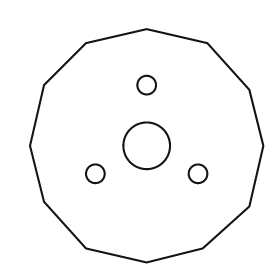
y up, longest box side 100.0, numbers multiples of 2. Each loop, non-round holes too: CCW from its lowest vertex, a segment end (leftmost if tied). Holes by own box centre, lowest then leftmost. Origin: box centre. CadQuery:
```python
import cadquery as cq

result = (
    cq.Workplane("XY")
    .moveTo(0.0, -50.0)
    .lineTo(24.0, -44.0)
    .lineTo(44.0, -26.0)
    .lineTo(50.0, 0.0)
    .lineTo(44.0, 24.0)
    .lineTo(26.0, 44.0)
    .lineTo(0.0, 50.0)
    .lineTo(-26.0, 44.0)
    .lineTo(-44.0, 26.0)
    .lineTo(-50.0, 0.0)
    .lineTo(-44.0, -24.0)
    .lineTo(-26.0, -44.0)
    .close()
    .moveTo(-22.0, -12.0)
    .circle(4.0)
    .moveTo(22.0, -12.0)
    .circle(4.0)
    .moveTo(0.0, 0.0)
    .circle(10.0)
    .moveTo(0.0, 26.0)
    .circle(4.0)
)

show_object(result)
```